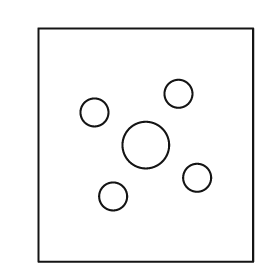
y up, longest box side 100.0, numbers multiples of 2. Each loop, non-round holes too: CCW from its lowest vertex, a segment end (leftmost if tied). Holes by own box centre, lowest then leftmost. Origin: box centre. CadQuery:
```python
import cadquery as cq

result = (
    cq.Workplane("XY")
    .moveTo(-46.0, -50.0)
    .lineTo(46.0, -50.0)
    .lineTo(46.0, 50.0)
    .lineTo(-46.0, 50.0)
    .close()
    .moveTo(-14.0, -22.0)
    .circle(6.0)
    .moveTo(22.0, -14.0)
    .circle(6.0)
    .moveTo(0.0, 0.0)
    .circle(10.0)
    .moveTo(-22.0, 14.0)
    .circle(6.0)
    .moveTo(14.0, 22.0)
    .circle(6.0)
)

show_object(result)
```